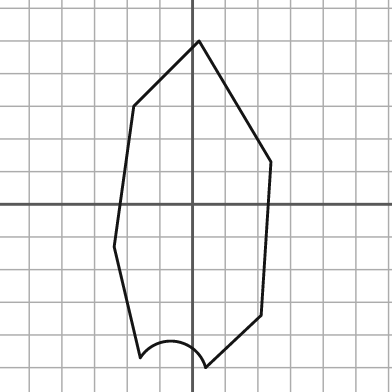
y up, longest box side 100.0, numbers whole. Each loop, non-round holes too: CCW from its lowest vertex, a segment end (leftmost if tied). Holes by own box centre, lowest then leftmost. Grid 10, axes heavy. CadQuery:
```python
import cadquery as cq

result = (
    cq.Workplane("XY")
    .moveTo(4.0, -50.0)
    .lineTo(21.0, -34.0)
    .lineTo(24.0, 13.0)
    .lineTo(2.0, 50.0)
    .lineTo(-18.0, 30.0)
    .lineTo(-24.0, -13.0)
    .lineTo(-16.0, -47.0)
    .threePointArc((-5.0, -42.0), (4.0, -50.0))
    .close()
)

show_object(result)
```